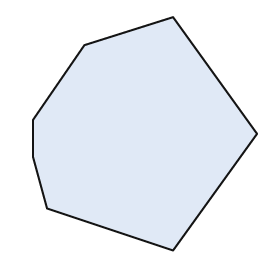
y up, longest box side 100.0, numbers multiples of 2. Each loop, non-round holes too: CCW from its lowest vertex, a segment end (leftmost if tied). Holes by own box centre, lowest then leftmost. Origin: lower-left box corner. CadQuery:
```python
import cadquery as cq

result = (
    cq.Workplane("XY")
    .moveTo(60.0, 0.0)
    .lineTo(96.0, 50.0)
    .lineTo(60.0, 100.0)
    .lineTo(22.0, 88.0)
    .lineTo(0.0, 56.0)
    .lineTo(0.0, 40.0)
    .lineTo(6.0, 18.0)
    .close()
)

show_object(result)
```